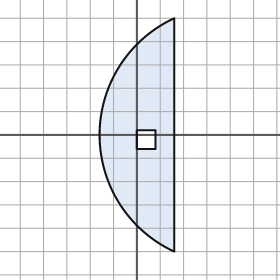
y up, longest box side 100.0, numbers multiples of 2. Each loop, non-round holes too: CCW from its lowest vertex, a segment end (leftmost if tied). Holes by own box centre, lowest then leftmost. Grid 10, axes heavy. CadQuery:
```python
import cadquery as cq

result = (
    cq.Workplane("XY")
    .moveTo(16.0, -50.0)
    .lineTo(16.0, 50.0)
    .threePointArc((-16.0, 0.0), (16.0, -50.0))
    .close()
    .moveTo(0.0, -6.0)
    .lineTo(8.0, -6.0)
    .lineTo(8.0, 2.0)
    .lineTo(0.0, 2.0)
    .close()
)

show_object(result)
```